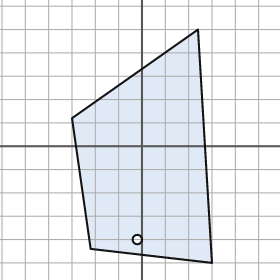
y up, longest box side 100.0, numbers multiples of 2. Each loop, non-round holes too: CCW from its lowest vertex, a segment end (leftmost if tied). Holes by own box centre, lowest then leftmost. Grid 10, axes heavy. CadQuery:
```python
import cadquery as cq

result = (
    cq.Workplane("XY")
    .moveTo(30.0, -50.0)
    .lineTo(24.0, 50.0)
    .lineTo(-30.0, 12.0)
    .lineTo(-22.0, -44.0)
    .close()
    .moveTo(-2.0, -40.0)
    .circle(2.0)
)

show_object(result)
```